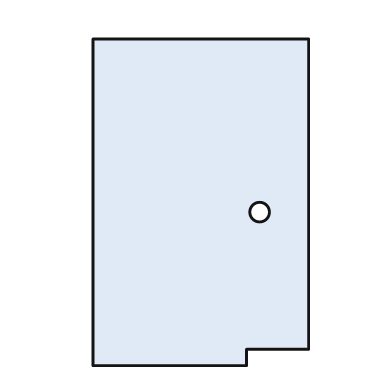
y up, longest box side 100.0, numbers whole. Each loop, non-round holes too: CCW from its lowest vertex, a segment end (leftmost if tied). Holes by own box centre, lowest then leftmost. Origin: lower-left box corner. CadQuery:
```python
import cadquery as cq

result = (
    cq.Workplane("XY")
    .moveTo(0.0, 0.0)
    .lineTo(47.0, 0.0)
    .lineTo(47.0, 5.0)
    .lineTo(66.0, 5.0)
    .lineTo(66.0, 100.0)
    .lineTo(0.0, 100.0)
    .close()
    .moveTo(51.0, 47.0)
    .circle(3.0)
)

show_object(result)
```